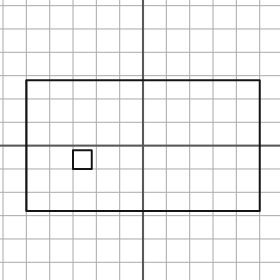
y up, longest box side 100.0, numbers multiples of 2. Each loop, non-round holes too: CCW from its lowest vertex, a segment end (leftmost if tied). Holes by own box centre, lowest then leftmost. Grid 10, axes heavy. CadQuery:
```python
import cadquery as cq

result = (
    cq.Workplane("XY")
    .moveTo(-50.0, -28.0)
    .lineTo(50.0, -28.0)
    .lineTo(50.0, 28.0)
    .lineTo(-50.0, 28.0)
    .close()
    .moveTo(-30.0, -10.0)
    .lineTo(-22.0, -10.0)
    .lineTo(-22.0, -2.0)
    .lineTo(-30.0, -2.0)
    .close()
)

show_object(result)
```